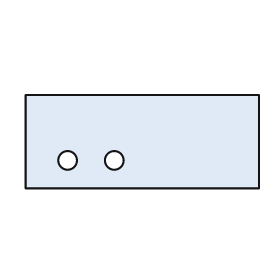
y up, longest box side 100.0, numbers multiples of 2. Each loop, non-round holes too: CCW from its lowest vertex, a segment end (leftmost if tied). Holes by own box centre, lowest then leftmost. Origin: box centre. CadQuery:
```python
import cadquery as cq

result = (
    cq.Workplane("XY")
    .moveTo(-50.0, -20.0)
    .lineTo(50.0, -20.0)
    .lineTo(50.0, 20.0)
    .lineTo(-50.0, 20.0)
    .close()
    .moveTo(-32.0, -8.0)
    .circle(4.0)
    .moveTo(-12.0, -8.0)
    .circle(4.0)
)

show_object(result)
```